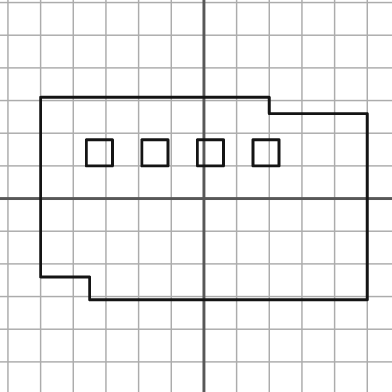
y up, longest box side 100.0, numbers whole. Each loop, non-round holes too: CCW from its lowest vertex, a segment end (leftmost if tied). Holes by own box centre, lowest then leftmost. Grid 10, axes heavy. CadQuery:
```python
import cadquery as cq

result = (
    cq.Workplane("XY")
    .moveTo(-35.0, -31.0)
    .lineTo(50.0, -31.0)
    .lineTo(50.0, 26.0)
    .lineTo(20.0, 26.0)
    .lineTo(20.0, 31.0)
    .lineTo(-50.0, 31.0)
    .lineTo(-50.0, -24.0)
    .lineTo(-35.0, -24.0)
    .close()
    .moveTo(-36.0, 10.0)
    .lineTo(-28.0, 10.0)
    .lineTo(-28.0, 18.0)
    .lineTo(-36.0, 18.0)
    .close()
    .moveTo(-19.0, 10.0)
    .lineTo(-11.0, 10.0)
    .lineTo(-11.0, 18.0)
    .lineTo(-19.0, 18.0)
    .close()
    .moveTo(-2.0, 10.0)
    .lineTo(6.0, 10.0)
    .lineTo(6.0, 18.0)
    .lineTo(-2.0, 18.0)
    .close()
    .moveTo(15.0, 10.0)
    .lineTo(23.0, 10.0)
    .lineTo(23.0, 18.0)
    .lineTo(15.0, 18.0)
    .close()
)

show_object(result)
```